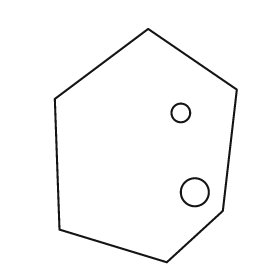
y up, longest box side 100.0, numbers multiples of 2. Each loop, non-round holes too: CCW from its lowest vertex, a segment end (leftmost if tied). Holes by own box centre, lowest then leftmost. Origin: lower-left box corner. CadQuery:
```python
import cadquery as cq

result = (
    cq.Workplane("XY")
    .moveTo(48.0, 0.0)
    .lineTo(72.0, 22.0)
    .lineTo(78.0, 74.0)
    .lineTo(40.0, 100.0)
    .lineTo(0.0, 70.0)
    .lineTo(2.0, 14.0)
    .close()
    .moveTo(60.0, 30.0)
    .circle(6.0)
    .moveTo(54.0, 64.0)
    .circle(4.0)
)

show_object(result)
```